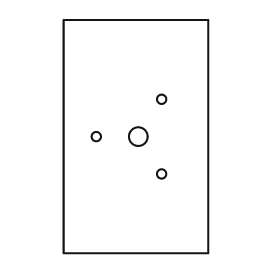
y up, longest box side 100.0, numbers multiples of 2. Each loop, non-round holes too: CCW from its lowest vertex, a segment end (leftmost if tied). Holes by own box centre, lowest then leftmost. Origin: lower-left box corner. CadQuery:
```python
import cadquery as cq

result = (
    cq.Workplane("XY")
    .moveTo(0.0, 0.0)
    .lineTo(62.0, 0.0)
    .lineTo(62.0, 100.0)
    .lineTo(0.0, 100.0)
    .close()
    .moveTo(42.0, 34.0)
    .circle(2.0)
    .moveTo(14.0, 50.0)
    .circle(2.0)
    .moveTo(32.0, 50.0)
    .circle(4.0)
    .moveTo(42.0, 66.0)
    .circle(2.0)
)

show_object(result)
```